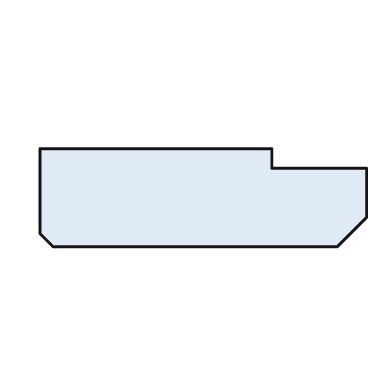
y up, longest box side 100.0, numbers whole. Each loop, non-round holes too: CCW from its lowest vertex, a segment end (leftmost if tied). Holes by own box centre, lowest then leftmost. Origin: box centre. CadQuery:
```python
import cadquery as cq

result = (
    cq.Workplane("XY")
    .moveTo(-46.0, -15.0)
    .lineTo(41.0, -15.0)
    .lineTo(50.0, -6.0)
    .lineTo(50.0, 9.0)
    .lineTo(21.0, 9.0)
    .lineTo(21.0, 15.0)
    .lineTo(-50.0, 15.0)
    .lineTo(-50.0, -11.0)
    .close()
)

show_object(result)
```